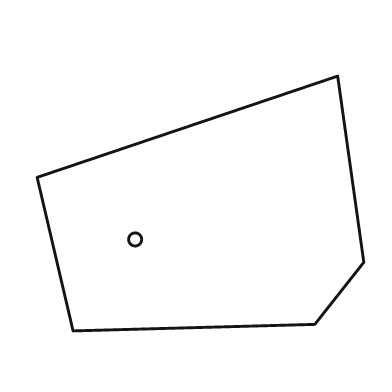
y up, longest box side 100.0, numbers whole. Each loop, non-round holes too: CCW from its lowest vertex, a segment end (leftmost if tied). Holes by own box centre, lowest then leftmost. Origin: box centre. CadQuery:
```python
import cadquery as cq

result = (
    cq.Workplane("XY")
    .moveTo(-39.0, -39.0)
    .lineTo(35.0, -37.0)
    .lineTo(50.0, -18.0)
    .lineTo(42.0, 39.0)
    .lineTo(-50.0, 8.0)
    .close()
    .moveTo(-20.0, -11.0)
    .circle(2.0)
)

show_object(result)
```